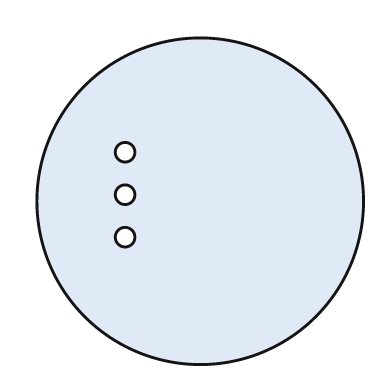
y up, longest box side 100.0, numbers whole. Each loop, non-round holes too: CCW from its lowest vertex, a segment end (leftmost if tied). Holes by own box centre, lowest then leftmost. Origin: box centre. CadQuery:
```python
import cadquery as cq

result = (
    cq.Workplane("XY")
    .moveTo(0.0, 0.0)
    .circle(50.0)
    .moveTo(-23.0, -11.0)
    .circle(3.0)
    .moveTo(-23.0, 2.0)
    .circle(3.0)
    .moveTo(-23.0, 15.0)
    .circle(3.0)
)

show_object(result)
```